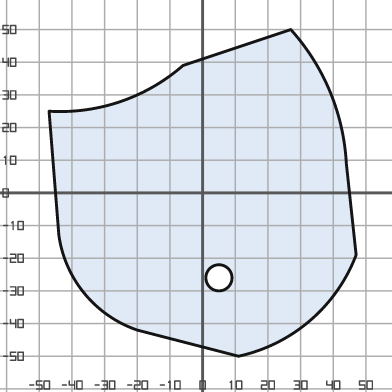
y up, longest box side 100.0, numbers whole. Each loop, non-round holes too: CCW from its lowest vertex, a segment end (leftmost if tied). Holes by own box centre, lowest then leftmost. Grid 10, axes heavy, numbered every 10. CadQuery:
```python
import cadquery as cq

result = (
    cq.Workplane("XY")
    .moveTo(11.0, -50.0)
    .threePointArc((33.0, -39.0), (47.0, -19.0))
    .lineTo(44.0, 9.0)
    .threePointArc((39.0, 31.0), (27.0, 50.0))
    .lineTo(-6.0, 39.0)
    .threePointArc((-25.0, 28.0), (-47.0, 25.0))
    .lineTo(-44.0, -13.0)
    .threePointArc((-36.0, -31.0), (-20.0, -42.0))
    .close()
    .moveTo(5.0, -26.0)
    .circle(4.0)
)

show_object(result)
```